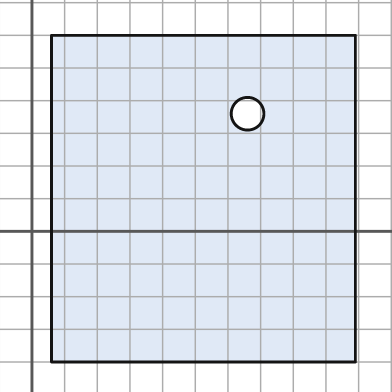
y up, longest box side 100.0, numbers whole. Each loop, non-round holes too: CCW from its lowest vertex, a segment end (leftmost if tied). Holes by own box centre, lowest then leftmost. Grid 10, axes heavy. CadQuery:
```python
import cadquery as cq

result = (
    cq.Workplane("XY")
    .moveTo(6.0, -40.0)
    .lineTo(99.0, -40.0)
    .lineTo(99.0, 60.0)
    .lineTo(6.0, 60.0)
    .close()
    .moveTo(66.0, 36.0)
    .circle(5.0)
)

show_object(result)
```